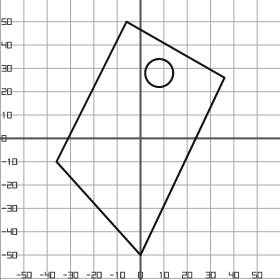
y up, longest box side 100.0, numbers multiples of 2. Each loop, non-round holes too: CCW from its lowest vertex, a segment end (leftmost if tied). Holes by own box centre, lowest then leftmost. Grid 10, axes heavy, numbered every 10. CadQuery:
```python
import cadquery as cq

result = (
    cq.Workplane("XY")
    .moveTo(0.0, -50.0)
    .lineTo(36.0, 26.0)
    .lineTo(-6.0, 50.0)
    .lineTo(-36.0, -10.0)
    .close()
    .moveTo(8.0, 28.0)
    .circle(6.0)
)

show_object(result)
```